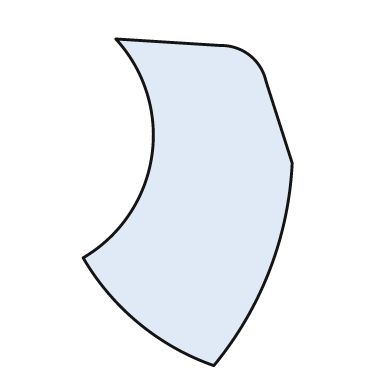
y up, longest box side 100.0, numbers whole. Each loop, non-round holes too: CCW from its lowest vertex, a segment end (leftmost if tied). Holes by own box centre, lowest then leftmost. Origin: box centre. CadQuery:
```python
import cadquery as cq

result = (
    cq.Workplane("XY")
    .moveTo(8.0, -50.0)
    .threePointArc((25.0, -21.0), (32.0, 12.0))
    .lineTo(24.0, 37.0)
    .threePointArc((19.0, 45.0), (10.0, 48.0))
    .lineTo(-22.0, 50.0)
    .threePointArc((-11.0, 14.0), (-32.0, -17.0))
    .threePointArc((-15.0, -37.0), (8.0, -50.0))
    .close()
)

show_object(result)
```